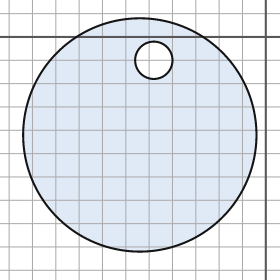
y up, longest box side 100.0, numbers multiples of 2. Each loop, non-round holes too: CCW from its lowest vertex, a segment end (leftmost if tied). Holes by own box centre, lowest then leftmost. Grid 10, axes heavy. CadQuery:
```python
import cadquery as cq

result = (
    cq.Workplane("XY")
    .moveTo(-54.0, -42.0)
    .circle(50.0)
    .moveTo(-48.0, -10.0)
    .circle(8.0)
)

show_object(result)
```